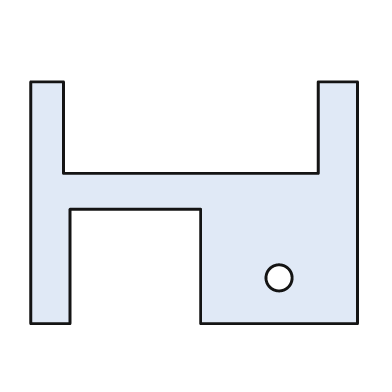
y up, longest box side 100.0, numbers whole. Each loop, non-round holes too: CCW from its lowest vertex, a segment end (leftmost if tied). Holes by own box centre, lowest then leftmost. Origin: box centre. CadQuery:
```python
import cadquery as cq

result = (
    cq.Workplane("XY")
    .moveTo(-50.0, -37.0)
    .lineTo(-38.0, -37.0)
    .lineTo(-38.0, -2.0)
    .lineTo(2.0, -2.0)
    .lineTo(2.0, -37.0)
    .lineTo(50.0, -37.0)
    .lineTo(50.0, 37.0)
    .lineTo(38.0, 37.0)
    .lineTo(38.0, 9.0)
    .lineTo(-40.0, 9.0)
    .lineTo(-40.0, 37.0)
    .lineTo(-50.0, 37.0)
    .close()
    .moveTo(26.0, -23.0)
    .circle(4.0)
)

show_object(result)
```